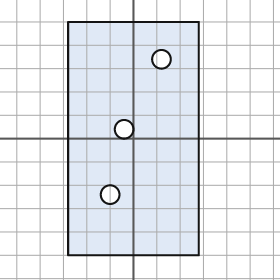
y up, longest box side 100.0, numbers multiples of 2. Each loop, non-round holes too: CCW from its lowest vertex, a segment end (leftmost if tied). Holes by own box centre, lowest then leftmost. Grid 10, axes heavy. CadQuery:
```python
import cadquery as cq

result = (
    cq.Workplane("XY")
    .moveTo(-28.0, -50.0)
    .lineTo(28.0, -50.0)
    .lineTo(28.0, 50.0)
    .lineTo(-28.0, 50.0)
    .close()
    .moveTo(-10.0, -24.0)
    .circle(4.0)
    .moveTo(-4.0, 4.0)
    .circle(4.0)
    .moveTo(12.0, 34.0)
    .circle(4.0)
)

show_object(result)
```